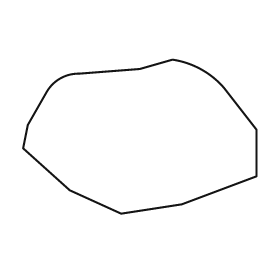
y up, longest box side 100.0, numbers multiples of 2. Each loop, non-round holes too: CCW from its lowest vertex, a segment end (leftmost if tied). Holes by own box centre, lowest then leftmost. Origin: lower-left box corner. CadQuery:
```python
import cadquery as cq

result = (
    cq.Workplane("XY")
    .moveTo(42.0, 0.0)
    .lineTo(68.0, 4.0)
    .lineTo(100.0, 16.0)
    .lineTo(100.0, 36.0)
    .lineTo(86.0, 54.0)
    .threePointArc((76.0, 62.0), (64.0, 66.0))
    .lineTo(50.0, 62.0)
    .lineTo(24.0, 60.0)
    .threePointArc((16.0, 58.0), (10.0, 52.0))
    .lineTo(2.0, 38.0)
    .lineTo(0.0, 28.0)
    .lineTo(20.0, 10.0)
    .close()
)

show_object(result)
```